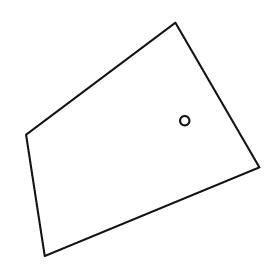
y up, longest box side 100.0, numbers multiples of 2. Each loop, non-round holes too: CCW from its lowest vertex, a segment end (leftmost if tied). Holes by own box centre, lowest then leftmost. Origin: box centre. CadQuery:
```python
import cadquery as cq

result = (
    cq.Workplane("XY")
    .moveTo(-42.0, -50.0)
    .lineTo(50.0, -12.0)
    .lineTo(14.0, 50.0)
    .lineTo(-50.0, 2.0)
    .close()
    .moveTo(18.0, 8.0)
    .circle(2.0)
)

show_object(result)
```